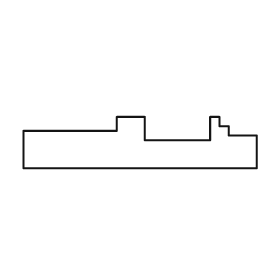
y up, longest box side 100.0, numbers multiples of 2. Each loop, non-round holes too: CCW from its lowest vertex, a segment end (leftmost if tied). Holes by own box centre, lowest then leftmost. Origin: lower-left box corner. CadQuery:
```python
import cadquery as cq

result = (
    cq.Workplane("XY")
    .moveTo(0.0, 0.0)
    .lineTo(100.0, 0.0)
    .lineTo(100.0, 14.0)
    .lineTo(88.0, 14.0)
    .lineTo(88.0, 18.0)
    .lineTo(84.0, 18.0)
    .lineTo(84.0, 22.0)
    .lineTo(80.0, 22.0)
    .lineTo(80.0, 12.0)
    .lineTo(52.0, 12.0)
    .lineTo(52.0, 22.0)
    .lineTo(40.0, 22.0)
    .lineTo(40.0, 16.0)
    .lineTo(0.0, 16.0)
    .close()
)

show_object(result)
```